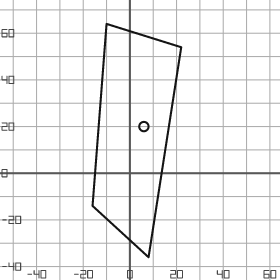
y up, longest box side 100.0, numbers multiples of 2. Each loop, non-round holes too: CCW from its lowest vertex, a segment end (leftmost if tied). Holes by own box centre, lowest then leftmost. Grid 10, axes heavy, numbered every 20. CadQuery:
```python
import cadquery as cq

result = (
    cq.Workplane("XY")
    .moveTo(8.0, -36.0)
    .lineTo(22.0, 54.0)
    .lineTo(-10.0, 64.0)
    .lineTo(-16.0, -14.0)
    .close()
    .moveTo(6.0, 20.0)
    .circle(2.0)
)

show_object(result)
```